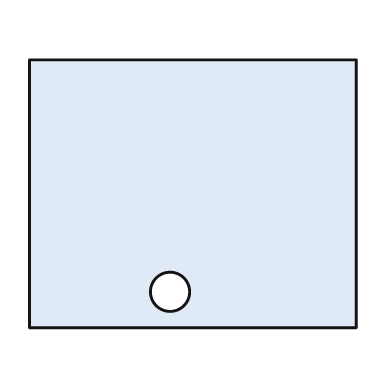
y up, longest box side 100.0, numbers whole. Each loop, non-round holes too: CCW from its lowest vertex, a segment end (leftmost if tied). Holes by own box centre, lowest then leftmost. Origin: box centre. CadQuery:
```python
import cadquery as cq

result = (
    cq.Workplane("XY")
    .moveTo(-50.0, -41.0)
    .lineTo(50.0, -41.0)
    .lineTo(50.0, 41.0)
    .lineTo(-50.0, 41.0)
    .close()
    .moveTo(-7.0, -30.0)
    .circle(6.0)
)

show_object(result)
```